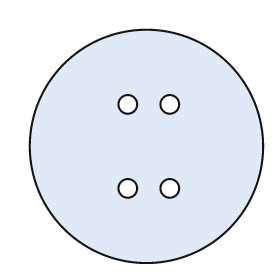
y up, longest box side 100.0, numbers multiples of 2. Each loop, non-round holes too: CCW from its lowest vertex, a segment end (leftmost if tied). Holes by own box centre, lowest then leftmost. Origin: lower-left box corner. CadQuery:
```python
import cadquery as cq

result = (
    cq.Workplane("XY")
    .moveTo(50.0, 50.0)
    .circle(50.0)
    .moveTo(42.0, 32.0)
    .circle(4.0)
    .moveTo(60.0, 32.0)
    .circle(4.0)
    .moveTo(42.0, 68.0)
    .circle(4.0)
    .moveTo(60.0, 68.0)
    .circle(4.0)
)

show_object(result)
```